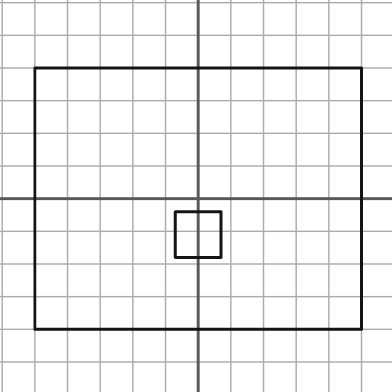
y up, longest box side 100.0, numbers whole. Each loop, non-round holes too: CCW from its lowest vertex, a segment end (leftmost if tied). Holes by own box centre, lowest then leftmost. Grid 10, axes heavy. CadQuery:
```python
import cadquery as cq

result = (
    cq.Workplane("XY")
    .moveTo(-50.0, -40.0)
    .lineTo(50.0, -40.0)
    .lineTo(50.0, 40.0)
    .lineTo(-50.0, 40.0)
    .close()
    .moveTo(-7.0, -18.0)
    .lineTo(7.0, -18.0)
    .lineTo(7.0, -4.0)
    .lineTo(-7.0, -4.0)
    .close()
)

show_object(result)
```